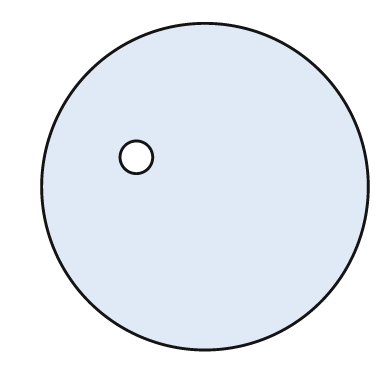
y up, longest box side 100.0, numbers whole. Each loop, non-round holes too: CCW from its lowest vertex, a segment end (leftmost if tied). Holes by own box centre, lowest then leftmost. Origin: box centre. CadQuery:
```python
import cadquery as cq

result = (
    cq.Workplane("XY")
    .moveTo(0.0, 0.0)
    .circle(50.0)
    .moveTo(-21.0, 9.0)
    .circle(5.0)
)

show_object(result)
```